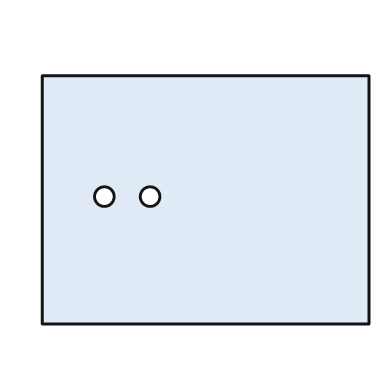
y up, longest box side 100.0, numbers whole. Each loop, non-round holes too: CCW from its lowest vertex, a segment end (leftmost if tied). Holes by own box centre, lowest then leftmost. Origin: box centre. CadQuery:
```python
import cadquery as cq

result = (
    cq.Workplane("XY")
    .moveTo(-50.0, -38.0)
    .lineTo(50.0, -38.0)
    .lineTo(50.0, 38.0)
    .lineTo(-50.0, 38.0)
    .close()
    .moveTo(-31.0, 1.0)
    .circle(3.0)
    .moveTo(-17.0, 1.0)
    .circle(3.0)
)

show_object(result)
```